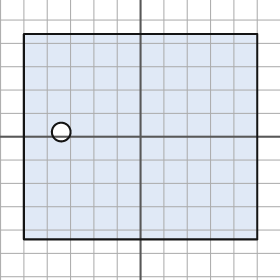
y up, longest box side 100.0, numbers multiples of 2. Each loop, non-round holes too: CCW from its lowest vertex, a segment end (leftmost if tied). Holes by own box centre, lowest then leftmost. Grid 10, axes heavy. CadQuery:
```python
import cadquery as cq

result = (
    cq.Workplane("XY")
    .moveTo(-50.0, -44.0)
    .lineTo(50.0, -44.0)
    .lineTo(50.0, 44.0)
    .lineTo(-50.0, 44.0)
    .close()
    .moveTo(-34.0, 2.0)
    .circle(4.0)
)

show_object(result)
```